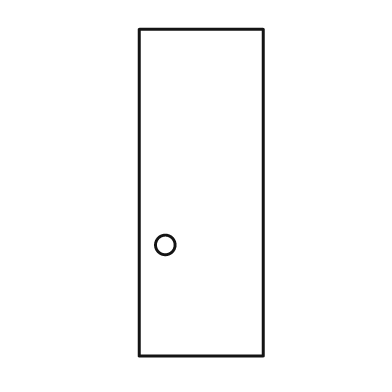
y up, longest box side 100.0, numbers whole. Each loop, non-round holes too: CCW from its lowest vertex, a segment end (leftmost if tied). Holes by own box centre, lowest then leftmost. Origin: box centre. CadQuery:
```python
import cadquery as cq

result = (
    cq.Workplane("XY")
    .moveTo(-19.0, -50.0)
    .lineTo(19.0, -50.0)
    .lineTo(19.0, 50.0)
    .lineTo(-19.0, 50.0)
    .close()
    .moveTo(-11.0, -16.0)
    .circle(3.0)
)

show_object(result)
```